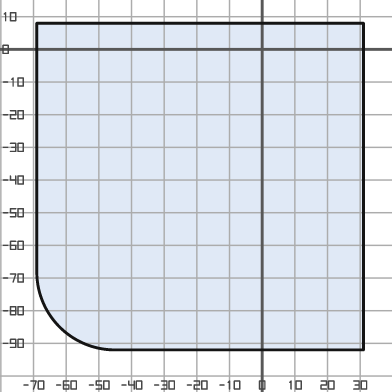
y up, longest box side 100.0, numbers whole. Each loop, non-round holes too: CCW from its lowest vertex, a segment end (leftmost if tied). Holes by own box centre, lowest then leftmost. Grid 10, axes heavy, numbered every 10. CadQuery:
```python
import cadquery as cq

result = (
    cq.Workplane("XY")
    .moveTo(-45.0, -92.0)
    .lineTo(31.0, -92.0)
    .lineTo(31.0, 8.0)
    .lineTo(-69.0, 8.0)
    .lineTo(-69.0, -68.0)
    .threePointArc((-62.0, -85.0), (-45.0, -92.0))
    .close()
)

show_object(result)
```